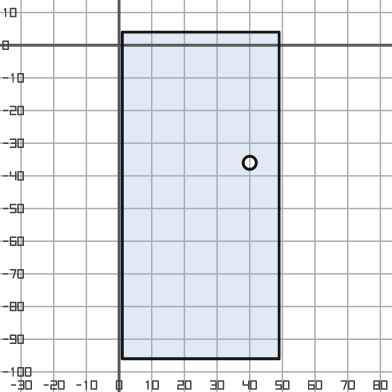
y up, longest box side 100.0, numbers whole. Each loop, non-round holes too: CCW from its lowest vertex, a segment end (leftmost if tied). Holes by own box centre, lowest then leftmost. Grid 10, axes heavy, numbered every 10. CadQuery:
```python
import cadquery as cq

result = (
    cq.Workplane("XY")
    .moveTo(1.0, -96.0)
    .lineTo(49.0, -96.0)
    .lineTo(49.0, 4.0)
    .lineTo(1.0, 4.0)
    .close()
    .moveTo(40.0, -36.0)
    .circle(2.0)
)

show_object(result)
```